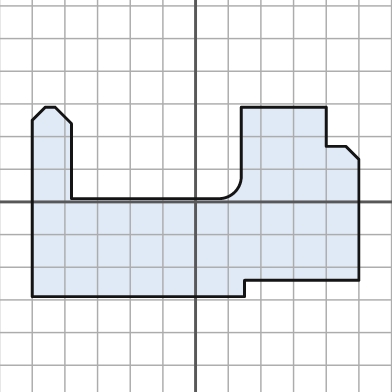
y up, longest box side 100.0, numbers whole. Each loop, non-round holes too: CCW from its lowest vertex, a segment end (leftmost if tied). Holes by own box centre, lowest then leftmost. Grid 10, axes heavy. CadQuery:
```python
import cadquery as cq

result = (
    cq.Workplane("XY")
    .moveTo(-50.0, -29.0)
    .lineTo(15.0, -29.0)
    .lineTo(15.0, -24.0)
    .lineTo(50.0, -24.0)
    .lineTo(50.0, 13.0)
    .lineTo(46.0, 17.0)
    .lineTo(40.0, 17.0)
    .lineTo(40.0, 29.0)
    .lineTo(14.0, 29.0)
    .lineTo(14.0, 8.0)
    .threePointArc((12.0, 3.0), (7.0, 1.0))
    .lineTo(-38.0, 1.0)
    .lineTo(-38.0, 24.0)
    .lineTo(-43.0, 29.0)
    .lineTo(-46.0, 29.0)
    .lineTo(-50.0, 25.0)
    .close()
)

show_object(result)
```